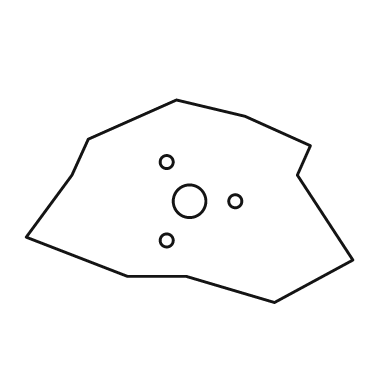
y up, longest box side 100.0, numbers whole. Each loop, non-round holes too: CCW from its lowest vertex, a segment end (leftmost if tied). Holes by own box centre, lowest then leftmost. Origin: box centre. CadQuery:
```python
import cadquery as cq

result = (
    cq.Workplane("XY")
    .moveTo(26.0, -31.0)
    .lineTo(50.0, -18.0)
    .lineTo(33.0, 8.0)
    .lineTo(37.0, 17.0)
    .lineTo(17.0, 26.0)
    .lineTo(-4.0, 31.0)
    .lineTo(-31.0, 19.0)
    .lineTo(-36.0, 8.0)
    .lineTo(-50.0, -11.0)
    .lineTo(-19.0, -23.0)
    .lineTo(-1.0, -23.0)
    .close()
    .moveTo(-7.0, -12.0)
    .circle(2.0)
    .moveTo(0.0, 0.0)
    .circle(5.0)
    .moveTo(14.0, 0.0)
    .circle(2.0)
    .moveTo(-7.0, 12.0)
    .circle(2.0)
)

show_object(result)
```